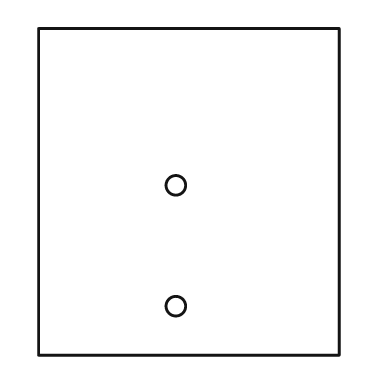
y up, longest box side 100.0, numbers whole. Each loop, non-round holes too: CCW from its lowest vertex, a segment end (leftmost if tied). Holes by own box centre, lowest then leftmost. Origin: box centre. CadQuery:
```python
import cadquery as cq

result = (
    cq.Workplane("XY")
    .moveTo(-46.0, -50.0)
    .lineTo(46.0, -50.0)
    .lineTo(46.0, 50.0)
    .lineTo(-46.0, 50.0)
    .close()
    .moveTo(-4.0, -35.0)
    .circle(3.0)
    .moveTo(-4.0, 2.0)
    .circle(3.0)
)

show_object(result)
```